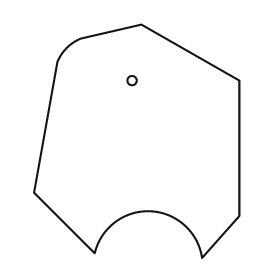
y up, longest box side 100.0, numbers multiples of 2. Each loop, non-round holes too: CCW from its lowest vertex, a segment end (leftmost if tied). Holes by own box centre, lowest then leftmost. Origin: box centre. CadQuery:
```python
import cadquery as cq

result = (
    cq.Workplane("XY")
    .moveTo(28.0, -50.0)
    .lineTo(44.0, -32.0)
    .lineTo(44.0, 26.0)
    .lineTo(2.0, 50.0)
    .lineTo(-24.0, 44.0)
    .threePointArc((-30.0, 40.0), (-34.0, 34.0))
    .lineTo(-44.0, -22.0)
    .lineTo(-18.0, -48.0)
    .threePointArc((6.0, -30.0), (28.0, -50.0))
    .close()
    .moveTo(-2.0, 26.0)
    .circle(2.0)
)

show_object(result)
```